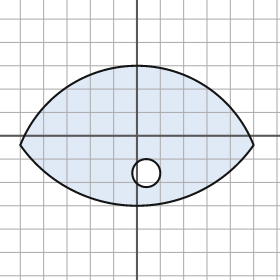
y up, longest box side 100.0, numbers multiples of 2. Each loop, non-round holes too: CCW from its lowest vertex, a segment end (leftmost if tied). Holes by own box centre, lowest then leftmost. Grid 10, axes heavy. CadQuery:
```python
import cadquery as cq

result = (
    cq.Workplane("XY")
    .moveTo(-50.0, -4.0)
    .threePointArc((0.0, -30.0), (50.0, -4.0))
    .threePointArc((0.0, 30.0), (-50.0, -4.0))
    .close()
    .moveTo(4.0, -16.0)
    .circle(6.0)
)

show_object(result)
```